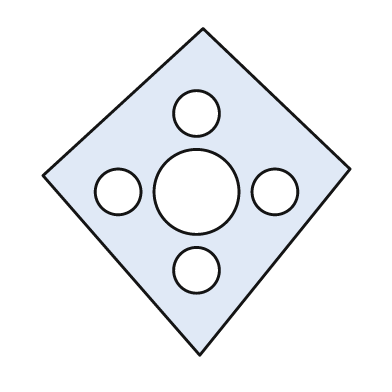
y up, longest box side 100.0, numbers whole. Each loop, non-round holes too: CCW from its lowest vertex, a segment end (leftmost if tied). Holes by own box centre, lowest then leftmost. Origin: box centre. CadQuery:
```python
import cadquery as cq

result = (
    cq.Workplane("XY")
    .moveTo(1.0, -50.0)
    .lineTo(47.0, 7.0)
    .lineTo(2.0, 50.0)
    .lineTo(-47.0, 5.0)
    .close()
    .moveTo(0.0, -24.0)
    .circle(7.0)
    .moveTo(-24.0, 0.0)
    .circle(7.0)
    .moveTo(0.0, 0.0)
    .circle(13.0)
    .moveTo(24.0, 0.0)
    .circle(7.0)
    .moveTo(0.0, 24.0)
    .circle(7.0)
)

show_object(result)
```